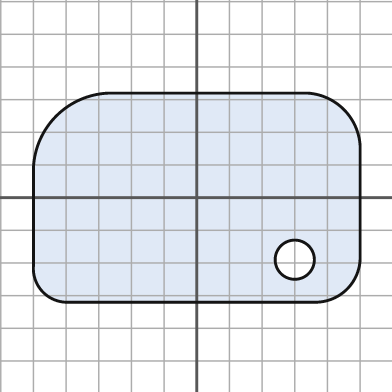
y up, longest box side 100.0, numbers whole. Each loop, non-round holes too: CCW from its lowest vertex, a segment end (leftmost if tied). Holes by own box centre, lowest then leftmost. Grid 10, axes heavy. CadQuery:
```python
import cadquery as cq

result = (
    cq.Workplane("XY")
    .moveTo(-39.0, -32.0)
    .lineTo(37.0, -32.0)
    .threePointArc((46.0, -28.0), (50.0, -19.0))
    .lineTo(50.0, 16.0)
    .threePointArc((45.0, 27.0), (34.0, 32.0))
    .lineTo(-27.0, 32.0)
    .threePointArc((-43.0, 25.0), (-50.0, 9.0))
    .lineTo(-50.0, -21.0)
    .threePointArc((-47.0, -29.0), (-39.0, -32.0))
    .close()
    .moveTo(30.0, -19.0)
    .circle(6.0)
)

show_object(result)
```